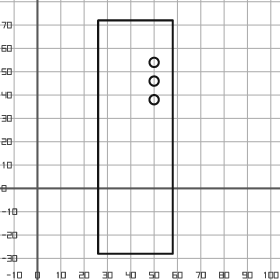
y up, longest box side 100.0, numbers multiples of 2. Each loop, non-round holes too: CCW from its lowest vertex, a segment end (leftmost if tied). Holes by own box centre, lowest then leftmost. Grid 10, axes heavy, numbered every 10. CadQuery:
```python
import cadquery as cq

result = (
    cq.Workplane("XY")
    .moveTo(26.0, -28.0)
    .lineTo(58.0, -28.0)
    .lineTo(58.0, 72.0)
    .lineTo(26.0, 72.0)
    .close()
    .moveTo(50.0, 38.0)
    .circle(2.0)
    .moveTo(50.0, 46.0)
    .circle(2.0)
    .moveTo(50.0, 54.0)
    .circle(2.0)
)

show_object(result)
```